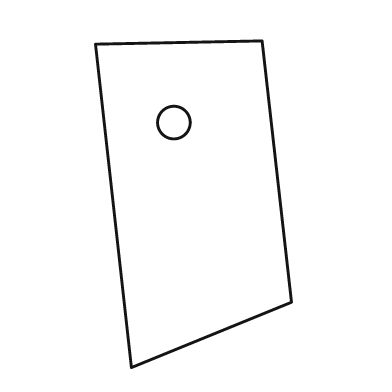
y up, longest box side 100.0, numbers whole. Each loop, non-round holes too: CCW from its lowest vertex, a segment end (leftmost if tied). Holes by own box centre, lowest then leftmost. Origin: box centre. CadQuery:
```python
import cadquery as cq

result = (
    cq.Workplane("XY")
    .moveTo(-19.0, -50.0)
    .lineTo(30.0, -30.0)
    .lineTo(21.0, 50.0)
    .lineTo(-30.0, 49.0)
    .close()
    .moveTo(-6.0, 25.0)
    .circle(5.0)
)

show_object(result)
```